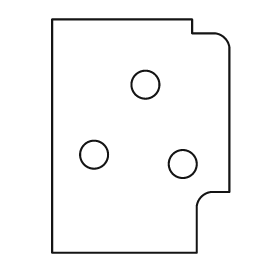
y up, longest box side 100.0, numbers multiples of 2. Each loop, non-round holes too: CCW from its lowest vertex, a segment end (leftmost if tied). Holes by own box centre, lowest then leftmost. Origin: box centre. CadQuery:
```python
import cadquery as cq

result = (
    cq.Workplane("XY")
    .moveTo(-38.0, -50.0)
    .lineTo(24.0, -50.0)
    .lineTo(24.0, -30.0)
    .threePointArc((26.0, -26.0), (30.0, -24.0))
    .lineTo(38.0, -24.0)
    .lineTo(38.0, 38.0)
    .threePointArc((36.0, 42.0), (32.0, 44.0))
    .lineTo(22.0, 44.0)
    .lineTo(22.0, 50.0)
    .lineTo(-38.0, 50.0)
    .close()
    .moveTo(18.0, -12.0)
    .circle(6.0)
    .moveTo(-20.0, -8.0)
    .circle(6.0)
    .moveTo(2.0, 22.0)
    .circle(6.0)
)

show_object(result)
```